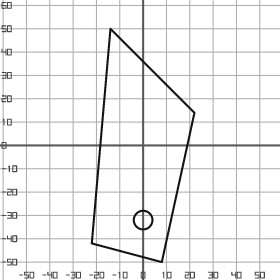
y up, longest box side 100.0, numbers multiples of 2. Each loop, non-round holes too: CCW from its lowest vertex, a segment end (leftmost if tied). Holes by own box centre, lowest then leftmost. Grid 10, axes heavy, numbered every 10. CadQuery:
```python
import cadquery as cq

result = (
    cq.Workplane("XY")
    .moveTo(8.0, -50.0)
    .lineTo(22.0, 14.0)
    .lineTo(-14.0, 50.0)
    .lineTo(-22.0, -42.0)
    .close()
    .moveTo(0.0, -32.0)
    .circle(4.0)
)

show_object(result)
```